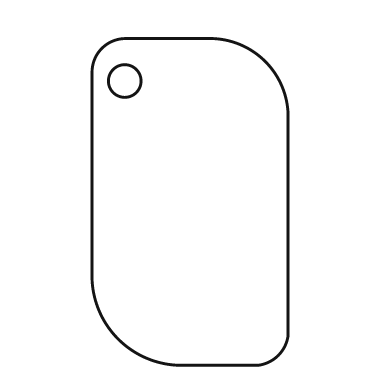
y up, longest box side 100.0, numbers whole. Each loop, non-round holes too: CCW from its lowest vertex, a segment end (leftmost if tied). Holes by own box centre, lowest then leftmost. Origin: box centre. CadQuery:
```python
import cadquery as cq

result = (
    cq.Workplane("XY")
    .moveTo(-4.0, -50.0)
    .lineTo(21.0, -50.0)
    .threePointArc((27.0, -47.0), (30.0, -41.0))
    .lineTo(30.0, 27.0)
    .threePointArc((23.0, 43.0), (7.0, 50.0))
    .lineTo(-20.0, 50.0)
    .threePointArc((-27.0, 47.0), (-30.0, 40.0))
    .lineTo(-30.0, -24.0)
    .threePointArc((-22.0, -42.0), (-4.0, -50.0))
    .close()
    .moveTo(-20.0, 37.0)
    .circle(5.0)
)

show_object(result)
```